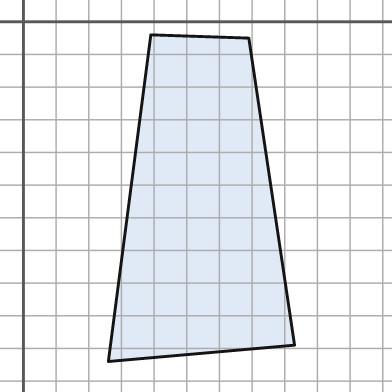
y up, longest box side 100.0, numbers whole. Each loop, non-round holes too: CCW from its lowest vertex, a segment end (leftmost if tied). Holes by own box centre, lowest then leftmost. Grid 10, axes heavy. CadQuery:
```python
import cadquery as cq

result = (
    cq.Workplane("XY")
    .moveTo(26.0, -104.0)
    .lineTo(83.0, -99.0)
    .lineTo(69.0, -5.0)
    .lineTo(39.0, -4.0)
    .close()
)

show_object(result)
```